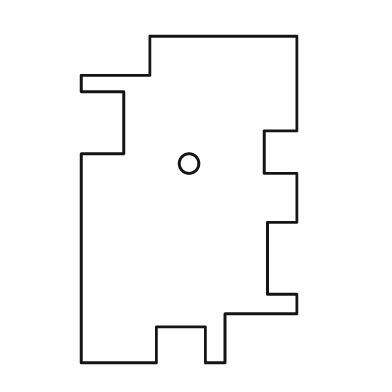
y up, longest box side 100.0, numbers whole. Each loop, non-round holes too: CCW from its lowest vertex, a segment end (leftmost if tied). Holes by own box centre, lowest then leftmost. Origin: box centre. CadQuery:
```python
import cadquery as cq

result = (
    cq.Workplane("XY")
    .moveTo(-33.0, -50.0)
    .lineTo(-10.0, -50.0)
    .lineTo(-10.0, -39.0)
    .lineTo(5.0, -39.0)
    .lineTo(5.0, -50.0)
    .lineTo(11.0, -50.0)
    .lineTo(11.0, -35.0)
    .lineTo(33.0, -35.0)
    .lineTo(33.0, -29.0)
    .lineTo(24.0, -29.0)
    .lineTo(24.0, -7.0)
    .lineTo(33.0, -7.0)
    .lineTo(33.0, 8.0)
    .lineTo(23.0, 8.0)
    .lineTo(23.0, 21.0)
    .lineTo(33.0, 21.0)
    .lineTo(33.0, 50.0)
    .lineTo(-12.0, 50.0)
    .lineTo(-12.0, 38.0)
    .lineTo(-33.0, 38.0)
    .lineTo(-33.0, 33.0)
    .lineTo(-20.0, 33.0)
    .lineTo(-20.0, 14.0)
    .lineTo(-33.0, 14.0)
    .close()
    .moveTo(0.0, 11.0)
    .circle(3.0)
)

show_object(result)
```